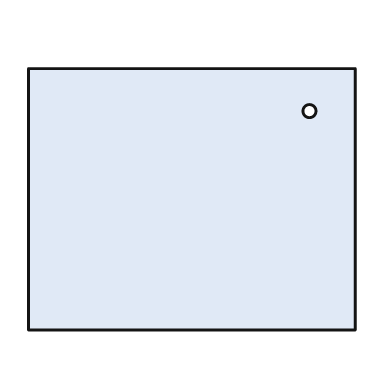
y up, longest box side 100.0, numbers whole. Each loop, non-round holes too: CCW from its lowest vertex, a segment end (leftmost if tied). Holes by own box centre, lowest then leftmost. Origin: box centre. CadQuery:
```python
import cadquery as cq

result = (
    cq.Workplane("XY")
    .moveTo(-50.0, -40.0)
    .lineTo(50.0, -40.0)
    .lineTo(50.0, 40.0)
    .lineTo(-50.0, 40.0)
    .close()
    .moveTo(36.0, 27.0)
    .circle(2.0)
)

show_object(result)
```